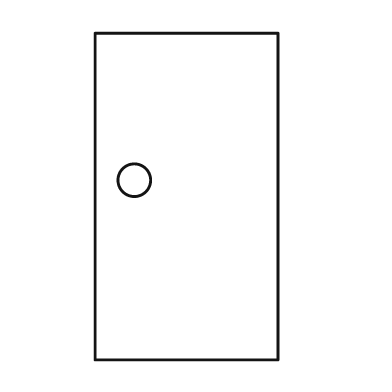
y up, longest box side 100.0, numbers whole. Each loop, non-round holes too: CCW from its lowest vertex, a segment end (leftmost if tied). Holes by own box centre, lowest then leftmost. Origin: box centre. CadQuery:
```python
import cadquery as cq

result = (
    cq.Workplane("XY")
    .moveTo(-28.0, -50.0)
    .lineTo(28.0, -50.0)
    .lineTo(28.0, 50.0)
    .lineTo(-28.0, 50.0)
    .close()
    .moveTo(-16.0, 5.0)
    .circle(5.0)
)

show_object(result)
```